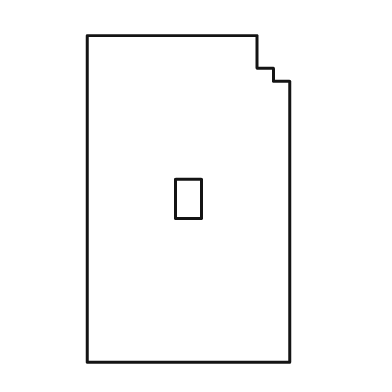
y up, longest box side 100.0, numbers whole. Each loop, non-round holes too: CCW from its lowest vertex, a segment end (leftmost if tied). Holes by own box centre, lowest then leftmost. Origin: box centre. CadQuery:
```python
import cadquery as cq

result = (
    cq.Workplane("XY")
    .moveTo(-31.0, -50.0)
    .lineTo(31.0, -50.0)
    .lineTo(31.0, 36.0)
    .lineTo(26.0, 36.0)
    .lineTo(26.0, 40.0)
    .lineTo(21.0, 40.0)
    .lineTo(21.0, 50.0)
    .lineTo(-31.0, 50.0)
    .close()
    .moveTo(-4.0, -6.0)
    .lineTo(4.0, -6.0)
    .lineTo(4.0, 6.0)
    .lineTo(-4.0, 6.0)
    .close()
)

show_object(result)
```